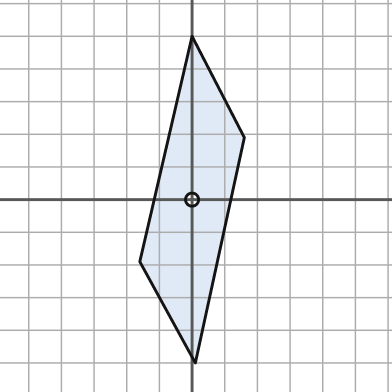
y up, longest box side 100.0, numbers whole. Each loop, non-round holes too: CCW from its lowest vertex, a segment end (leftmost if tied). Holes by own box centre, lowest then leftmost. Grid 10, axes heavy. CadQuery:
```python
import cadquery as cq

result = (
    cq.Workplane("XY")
    .moveTo(1.0, -50.0)
    .lineTo(16.0, 19.0)
    .lineTo(0.0, 50.0)
    .lineTo(-16.0, -19.0)
    .close()
    .moveTo(0.0, 0.0)
    .circle(2.0)
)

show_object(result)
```